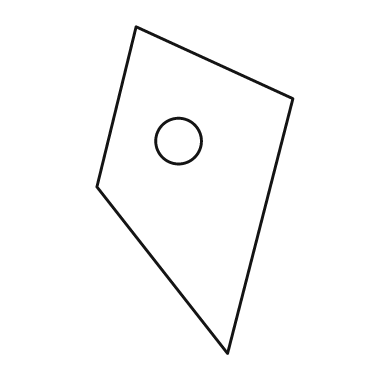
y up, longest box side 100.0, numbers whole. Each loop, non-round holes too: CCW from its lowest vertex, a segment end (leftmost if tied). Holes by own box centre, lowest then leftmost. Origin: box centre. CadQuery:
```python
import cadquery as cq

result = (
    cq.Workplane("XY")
    .moveTo(10.0, -50.0)
    .lineTo(30.0, 28.0)
    .lineTo(-18.0, 50.0)
    .lineTo(-30.0, 1.0)
    .close()
    .moveTo(-5.0, 15.0)
    .circle(7.0)
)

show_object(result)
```